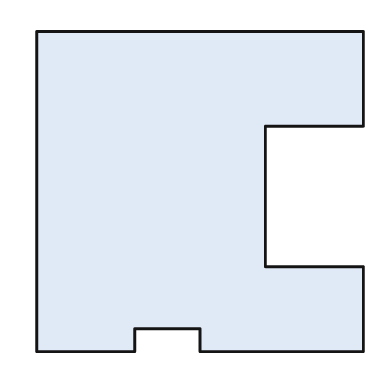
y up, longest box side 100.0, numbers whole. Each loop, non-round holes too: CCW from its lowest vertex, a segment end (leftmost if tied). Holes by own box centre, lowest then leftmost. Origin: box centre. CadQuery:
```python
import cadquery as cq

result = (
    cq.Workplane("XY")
    .moveTo(-50.0, -49.0)
    .lineTo(-20.0, -49.0)
    .lineTo(-20.0, -42.0)
    .lineTo(0.0, -42.0)
    .lineTo(0.0, -49.0)
    .lineTo(50.0, -49.0)
    .lineTo(50.0, -23.0)
    .lineTo(20.0, -23.0)
    .lineTo(20.0, 20.0)
    .lineTo(50.0, 20.0)
    .lineTo(50.0, 49.0)
    .lineTo(-50.0, 49.0)
    .close()
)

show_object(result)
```